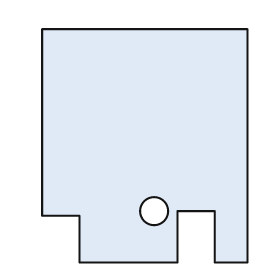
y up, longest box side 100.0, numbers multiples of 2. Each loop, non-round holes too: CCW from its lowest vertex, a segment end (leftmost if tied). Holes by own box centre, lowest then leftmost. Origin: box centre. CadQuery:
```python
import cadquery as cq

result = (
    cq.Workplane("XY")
    .moveTo(-28.0, -50.0)
    .lineTo(14.0, -50.0)
    .lineTo(14.0, -28.0)
    .lineTo(30.0, -28.0)
    .lineTo(30.0, -50.0)
    .lineTo(44.0, -50.0)
    .lineTo(44.0, 50.0)
    .lineTo(-44.0, 50.0)
    .lineTo(-44.0, -30.0)
    .lineTo(-28.0, -30.0)
    .close()
    .moveTo(4.0, -28.0)
    .circle(6.0)
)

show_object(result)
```